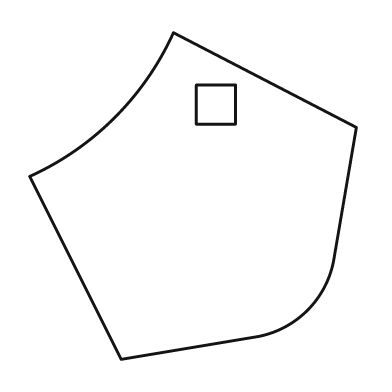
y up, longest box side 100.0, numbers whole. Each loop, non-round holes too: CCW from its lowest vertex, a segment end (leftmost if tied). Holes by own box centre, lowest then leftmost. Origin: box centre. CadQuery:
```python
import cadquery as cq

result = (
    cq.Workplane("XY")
    .moveTo(-22.0, -50.0)
    .lineTo(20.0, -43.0)
    .threePointArc((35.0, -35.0), (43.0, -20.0))
    .lineTo(50.0, 21.0)
    .lineTo(-6.0, 50.0)
    .threePointArc((-24.0, 24.0), (-50.0, 6.0))
    .close()
    .moveTo(1.0, 22.0)
    .lineTo(13.0, 22.0)
    .lineTo(13.0, 34.0)
    .lineTo(1.0, 34.0)
    .close()
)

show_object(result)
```